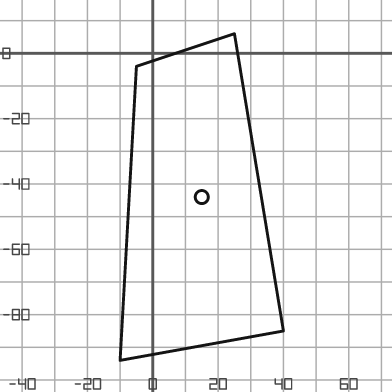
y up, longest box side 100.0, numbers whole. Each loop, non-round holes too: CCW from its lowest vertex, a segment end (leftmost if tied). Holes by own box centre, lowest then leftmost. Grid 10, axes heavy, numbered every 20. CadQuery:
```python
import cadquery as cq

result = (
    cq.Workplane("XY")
    .moveTo(-10.0, -94.0)
    .lineTo(40.0, -85.0)
    .lineTo(25.0, 6.0)
    .lineTo(-5.0, -4.0)
    .close()
    .moveTo(15.0, -44.0)
    .circle(2.0)
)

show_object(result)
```